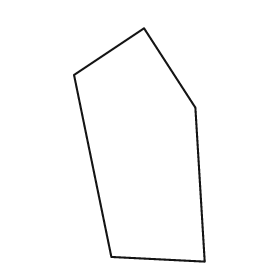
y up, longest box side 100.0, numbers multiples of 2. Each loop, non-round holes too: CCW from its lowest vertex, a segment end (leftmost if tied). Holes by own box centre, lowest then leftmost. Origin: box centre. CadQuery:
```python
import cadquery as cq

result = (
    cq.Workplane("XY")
    .moveTo(28.0, -50.0)
    .lineTo(24.0, 16.0)
    .lineTo(2.0, 50.0)
    .lineTo(-28.0, 30.0)
    .lineTo(-12.0, -48.0)
    .close()
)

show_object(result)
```